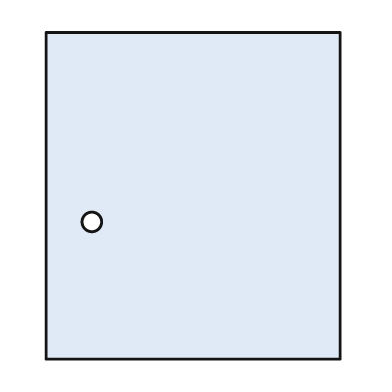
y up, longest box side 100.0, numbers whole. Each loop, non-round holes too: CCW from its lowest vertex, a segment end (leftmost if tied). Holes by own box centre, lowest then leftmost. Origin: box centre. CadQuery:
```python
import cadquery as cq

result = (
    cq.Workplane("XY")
    .moveTo(-45.0, -50.0)
    .lineTo(45.0, -50.0)
    .lineTo(45.0, 50.0)
    .lineTo(-45.0, 50.0)
    .close()
    .moveTo(-31.0, -8.0)
    .circle(3.0)
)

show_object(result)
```